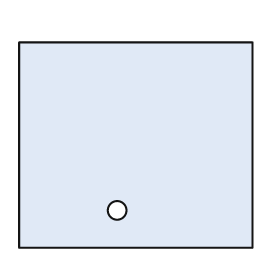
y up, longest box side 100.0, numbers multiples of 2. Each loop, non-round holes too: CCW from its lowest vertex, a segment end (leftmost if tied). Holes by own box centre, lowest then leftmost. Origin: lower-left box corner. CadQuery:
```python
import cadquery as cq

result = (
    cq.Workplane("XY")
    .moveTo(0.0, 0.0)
    .lineTo(100.0, 0.0)
    .lineTo(100.0, 88.0)
    .lineTo(0.0, 88.0)
    .close()
    .moveTo(42.0, 16.0)
    .circle(4.0)
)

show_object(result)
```